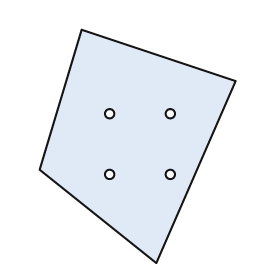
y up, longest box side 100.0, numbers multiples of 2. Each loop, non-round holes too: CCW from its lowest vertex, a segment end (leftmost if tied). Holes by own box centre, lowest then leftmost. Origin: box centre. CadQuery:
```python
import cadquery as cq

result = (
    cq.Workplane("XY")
    .moveTo(8.0, -50.0)
    .lineTo(42.0, 28.0)
    .lineTo(-24.0, 50.0)
    .lineTo(-42.0, -10.0)
    .close()
    .moveTo(-12.0, -12.0)
    .circle(2.0)
    .moveTo(14.0, -12.0)
    .circle(2.0)
    .moveTo(-12.0, 14.0)
    .circle(2.0)
    .moveTo(14.0, 14.0)
    .circle(2.0)
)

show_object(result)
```